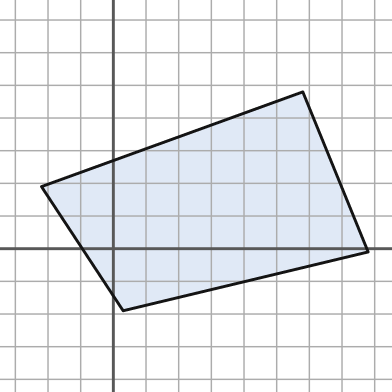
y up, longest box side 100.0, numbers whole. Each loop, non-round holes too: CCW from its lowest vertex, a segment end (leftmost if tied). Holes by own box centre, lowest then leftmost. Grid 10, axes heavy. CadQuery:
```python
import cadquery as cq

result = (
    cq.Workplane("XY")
    .moveTo(3.0, -19.0)
    .lineTo(78.0, -1.0)
    .lineTo(58.0, 48.0)
    .lineTo(-22.0, 19.0)
    .close()
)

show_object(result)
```